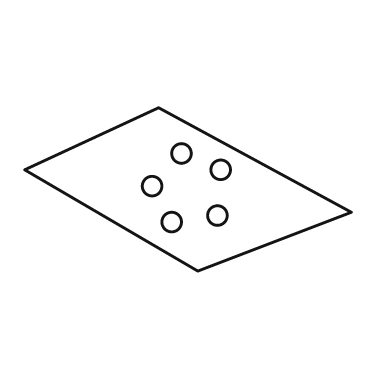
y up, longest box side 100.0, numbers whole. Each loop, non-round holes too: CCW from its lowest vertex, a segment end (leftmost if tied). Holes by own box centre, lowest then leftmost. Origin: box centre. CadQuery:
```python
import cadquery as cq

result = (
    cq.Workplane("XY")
    .moveTo(3.0, -25.0)
    .lineTo(50.0, -7.0)
    .lineTo(-9.0, 25.0)
    .lineTo(-50.0, 6.0)
    .close()
    .moveTo(-5.0, -10.0)
    .circle(3.0)
    .moveTo(9.0, -8.0)
    .circle(3.0)
    .moveTo(-11.0, 1.0)
    .circle(3.0)
    .moveTo(10.0, 6.0)
    .circle(3.0)
    .moveTo(-2.0, 11.0)
    .circle(3.0)
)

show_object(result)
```